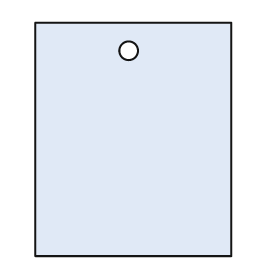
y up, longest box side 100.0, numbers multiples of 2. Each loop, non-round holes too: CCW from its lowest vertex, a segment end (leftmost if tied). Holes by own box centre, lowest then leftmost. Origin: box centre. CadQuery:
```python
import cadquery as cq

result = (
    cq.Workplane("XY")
    .moveTo(-42.0, -50.0)
    .lineTo(42.0, -50.0)
    .lineTo(42.0, 50.0)
    .lineTo(-42.0, 50.0)
    .close()
    .moveTo(-2.0, 38.0)
    .circle(4.0)
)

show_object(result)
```